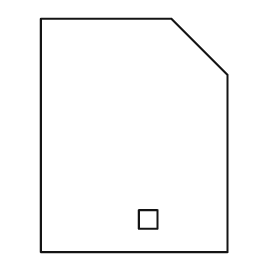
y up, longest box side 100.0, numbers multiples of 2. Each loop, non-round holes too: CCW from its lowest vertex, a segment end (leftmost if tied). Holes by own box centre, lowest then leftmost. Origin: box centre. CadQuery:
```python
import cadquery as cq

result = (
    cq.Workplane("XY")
    .moveTo(-40.0, -50.0)
    .lineTo(40.0, -50.0)
    .lineTo(40.0, 26.0)
    .lineTo(16.0, 50.0)
    .lineTo(-40.0, 50.0)
    .close()
    .moveTo(2.0, -40.0)
    .lineTo(10.0, -40.0)
    .lineTo(10.0, -32.0)
    .lineTo(2.0, -32.0)
    .close()
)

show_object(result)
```